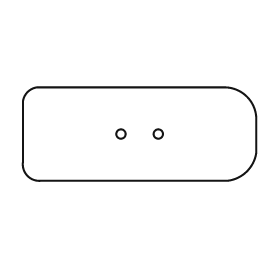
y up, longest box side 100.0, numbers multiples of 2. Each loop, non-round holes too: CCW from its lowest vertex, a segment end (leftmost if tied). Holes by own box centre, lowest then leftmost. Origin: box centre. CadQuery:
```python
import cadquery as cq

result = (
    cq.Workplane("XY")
    .moveTo(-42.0, -20.0)
    .lineTo(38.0, -20.0)
    .threePointArc((46.0, -16.0), (50.0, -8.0))
    .lineTo(50.0, 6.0)
    .threePointArc((46.0, 16.0), (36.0, 20.0))
    .lineTo(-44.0, 20.0)
    .threePointArc((-48.0, 18.0), (-50.0, 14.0))
    .lineTo(-50.0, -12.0)
    .threePointArc((-48.0, -18.0), (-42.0, -20.0))
    .close()
    .moveTo(-8.0, 0.0)
    .circle(2.0)
    .moveTo(8.0, 0.0)
    .circle(2.0)
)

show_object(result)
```